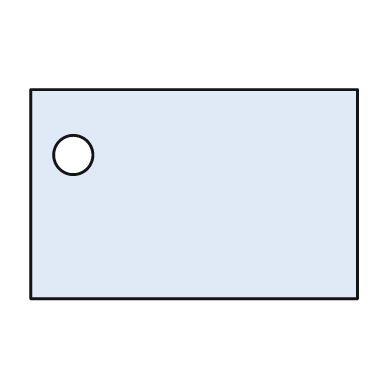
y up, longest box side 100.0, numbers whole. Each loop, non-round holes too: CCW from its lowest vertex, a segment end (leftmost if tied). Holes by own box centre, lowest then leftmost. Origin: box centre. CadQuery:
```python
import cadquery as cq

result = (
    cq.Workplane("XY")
    .moveTo(-50.0, -32.0)
    .lineTo(50.0, -32.0)
    .lineTo(50.0, 32.0)
    .lineTo(-50.0, 32.0)
    .close()
    .moveTo(-37.0, 12.0)
    .circle(6.0)
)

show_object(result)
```